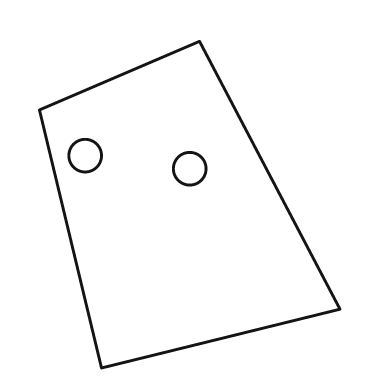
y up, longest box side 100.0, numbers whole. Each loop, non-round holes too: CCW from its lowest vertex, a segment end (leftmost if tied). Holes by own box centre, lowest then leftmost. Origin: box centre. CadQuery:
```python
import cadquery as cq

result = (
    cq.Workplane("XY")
    .moveTo(-27.0, -50.0)
    .lineTo(46.0, -32.0)
    .lineTo(3.0, 50.0)
    .lineTo(-46.0, 29.0)
    .close()
    .moveTo(0.0, 11.0)
    .circle(5.0)
    .moveTo(-32.0, 15.0)
    .circle(5.0)
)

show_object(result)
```